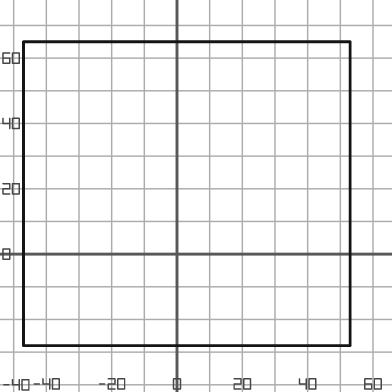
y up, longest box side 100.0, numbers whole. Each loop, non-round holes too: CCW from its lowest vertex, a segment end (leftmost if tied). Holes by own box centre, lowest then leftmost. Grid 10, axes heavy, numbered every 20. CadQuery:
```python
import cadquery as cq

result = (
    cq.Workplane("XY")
    .moveTo(-47.0, -28.0)
    .lineTo(53.0, -28.0)
    .lineTo(53.0, 65.0)
    .lineTo(-47.0, 65.0)
    .close()
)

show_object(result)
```